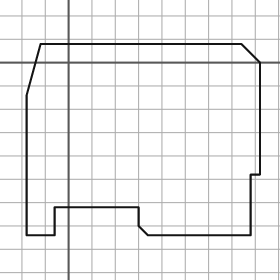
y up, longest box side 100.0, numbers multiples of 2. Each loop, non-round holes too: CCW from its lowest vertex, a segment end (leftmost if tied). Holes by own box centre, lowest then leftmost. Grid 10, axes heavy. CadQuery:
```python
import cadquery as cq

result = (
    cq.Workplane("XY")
    .moveTo(-18.0, -74.0)
    .lineTo(-6.0, -74.0)
    .lineTo(-6.0, -62.0)
    .lineTo(30.0, -62.0)
    .lineTo(30.0, -70.0)
    .lineTo(34.0, -74.0)
    .lineTo(78.0, -74.0)
    .lineTo(78.0, -48.0)
    .lineTo(82.0, -48.0)
    .lineTo(82.0, 0.0)
    .lineTo(74.0, 8.0)
    .lineTo(-12.0, 8.0)
    .lineTo(-18.0, -14.0)
    .close()
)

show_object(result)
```